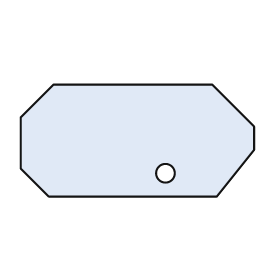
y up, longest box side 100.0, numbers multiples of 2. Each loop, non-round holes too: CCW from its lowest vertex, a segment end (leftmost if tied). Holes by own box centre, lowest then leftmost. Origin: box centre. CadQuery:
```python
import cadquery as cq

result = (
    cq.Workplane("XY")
    .moveTo(-38.0, -24.0)
    .lineTo(34.0, -24.0)
    .lineTo(50.0, -4.0)
    .lineTo(50.0, 6.0)
    .lineTo(32.0, 24.0)
    .lineTo(-36.0, 24.0)
    .lineTo(-50.0, 10.0)
    .lineTo(-50.0, -12.0)
    .close()
    .moveTo(12.0, -14.0)
    .circle(4.0)
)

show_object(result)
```